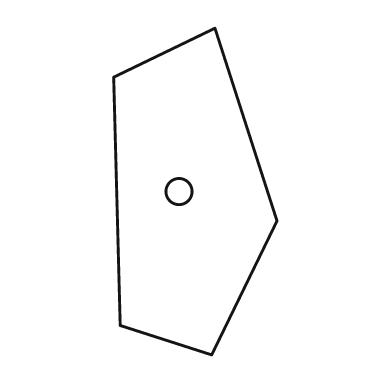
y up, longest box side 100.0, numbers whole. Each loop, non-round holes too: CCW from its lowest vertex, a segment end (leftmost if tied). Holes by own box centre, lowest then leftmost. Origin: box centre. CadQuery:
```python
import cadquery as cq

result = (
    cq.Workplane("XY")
    .moveTo(5.0, -50.0)
    .lineTo(25.0, -9.0)
    .lineTo(6.0, 50.0)
    .lineTo(-25.0, 35.0)
    .lineTo(-23.0, -41.0)
    .close()
    .moveTo(-5.0, 0.0)
    .circle(4.0)
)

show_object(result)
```